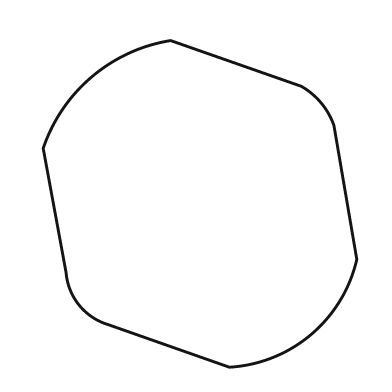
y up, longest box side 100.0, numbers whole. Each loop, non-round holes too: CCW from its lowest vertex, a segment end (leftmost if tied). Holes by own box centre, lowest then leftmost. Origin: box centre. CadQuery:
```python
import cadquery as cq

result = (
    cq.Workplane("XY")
    .moveTo(9.0, -50.0)
    .threePointArc((34.0, -40.0), (48.0, -17.0))
    .lineTo(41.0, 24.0)
    .threePointArc((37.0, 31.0), (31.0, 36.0))
    .lineTo(-9.0, 50.0)
    .threePointArc((-33.0, 39.0), (-48.0, 17.0))
    .lineTo(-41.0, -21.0)
    .threePointArc((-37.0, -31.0), (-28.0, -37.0))
    .close()
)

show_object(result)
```